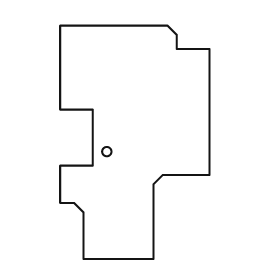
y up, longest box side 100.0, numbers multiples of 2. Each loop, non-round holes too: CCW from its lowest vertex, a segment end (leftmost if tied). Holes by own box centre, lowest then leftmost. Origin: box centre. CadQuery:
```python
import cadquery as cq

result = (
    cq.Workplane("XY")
    .moveTo(-22.0, -50.0)
    .lineTo(8.0, -50.0)
    .lineTo(8.0, -18.0)
    .lineTo(12.0, -14.0)
    .lineTo(32.0, -14.0)
    .lineTo(32.0, 40.0)
    .lineTo(18.0, 40.0)
    .lineTo(18.0, 46.0)
    .lineTo(14.0, 50.0)
    .lineTo(-32.0, 50.0)
    .lineTo(-32.0, 14.0)
    .lineTo(-18.0, 14.0)
    .lineTo(-18.0, -10.0)
    .lineTo(-32.0, -10.0)
    .lineTo(-32.0, -26.0)
    .lineTo(-26.0, -26.0)
    .lineTo(-22.0, -30.0)
    .close()
    .moveTo(-12.0, -4.0)
    .circle(2.0)
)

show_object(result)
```